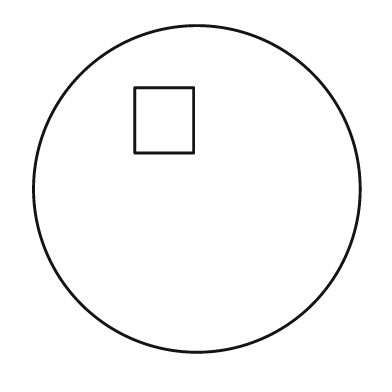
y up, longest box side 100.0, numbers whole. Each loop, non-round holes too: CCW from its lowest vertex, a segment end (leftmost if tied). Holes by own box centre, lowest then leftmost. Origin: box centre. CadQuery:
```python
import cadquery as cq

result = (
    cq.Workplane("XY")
    .moveTo(0.0, 0.0)
    .circle(50.0)
    .moveTo(-19.0, 11.0)
    .lineTo(-1.0, 11.0)
    .lineTo(-1.0, 31.0)
    .lineTo(-19.0, 31.0)
    .close()
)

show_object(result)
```